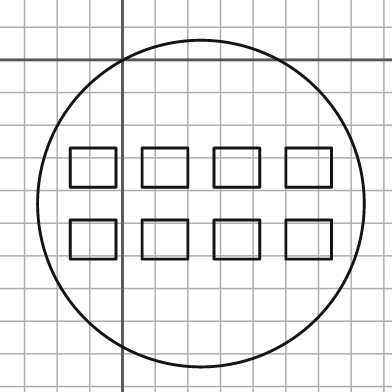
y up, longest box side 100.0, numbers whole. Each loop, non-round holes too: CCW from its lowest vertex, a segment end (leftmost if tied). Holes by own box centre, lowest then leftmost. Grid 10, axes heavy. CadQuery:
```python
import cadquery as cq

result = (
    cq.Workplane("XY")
    .moveTo(24.0, -44.0)
    .circle(50.0)
    .moveTo(-16.0, -61.0)
    .lineTo(-2.0, -61.0)
    .lineTo(-2.0, -49.0)
    .lineTo(-16.0, -49.0)
    .close()
    .moveTo(6.0, -61.0)
    .lineTo(20.0, -61.0)
    .lineTo(20.0, -49.0)
    .lineTo(6.0, -49.0)
    .close()
    .moveTo(28.0, -61.0)
    .lineTo(42.0, -61.0)
    .lineTo(42.0, -49.0)
    .lineTo(28.0, -49.0)
    .close()
    .moveTo(50.0, -61.0)
    .lineTo(64.0, -61.0)
    .lineTo(64.0, -49.0)
    .lineTo(50.0, -49.0)
    .close()
    .moveTo(-16.0, -39.0)
    .lineTo(-2.0, -39.0)
    .lineTo(-2.0, -27.0)
    .lineTo(-16.0, -27.0)
    .close()
    .moveTo(6.0, -39.0)
    .lineTo(20.0, -39.0)
    .lineTo(20.0, -27.0)
    .lineTo(6.0, -27.0)
    .close()
    .moveTo(28.0, -39.0)
    .lineTo(42.0, -39.0)
    .lineTo(42.0, -27.0)
    .lineTo(28.0, -27.0)
    .close()
    .moveTo(50.0, -39.0)
    .lineTo(64.0, -39.0)
    .lineTo(64.0, -27.0)
    .lineTo(50.0, -27.0)
    .close()
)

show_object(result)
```